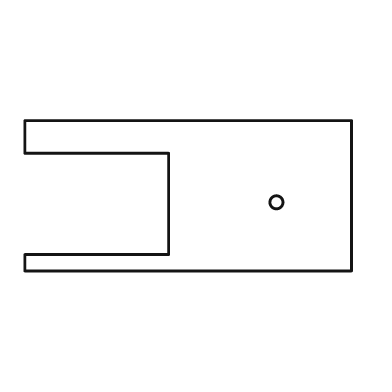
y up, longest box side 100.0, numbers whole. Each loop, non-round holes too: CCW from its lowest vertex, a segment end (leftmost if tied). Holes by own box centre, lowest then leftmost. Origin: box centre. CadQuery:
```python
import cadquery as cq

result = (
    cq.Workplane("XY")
    .moveTo(-50.0, -23.0)
    .lineTo(50.0, -23.0)
    .lineTo(50.0, 23.0)
    .lineTo(-50.0, 23.0)
    .lineTo(-50.0, 13.0)
    .lineTo(-6.0, 13.0)
    .lineTo(-6.0, -18.0)
    .lineTo(-50.0, -18.0)
    .close()
    .moveTo(27.0, -2.0)
    .circle(2.0)
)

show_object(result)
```